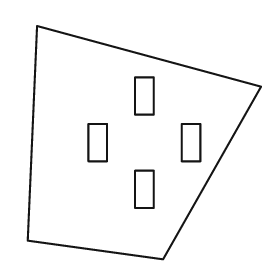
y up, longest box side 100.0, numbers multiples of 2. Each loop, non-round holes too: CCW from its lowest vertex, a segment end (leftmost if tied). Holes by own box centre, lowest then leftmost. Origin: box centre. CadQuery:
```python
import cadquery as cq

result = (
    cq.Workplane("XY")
    .moveTo(8.0, -50.0)
    .lineTo(50.0, 24.0)
    .lineTo(-46.0, 50.0)
    .lineTo(-50.0, -42.0)
    .close()
    .moveTo(-4.0, -28.0)
    .lineTo(4.0, -28.0)
    .lineTo(4.0, -12.0)
    .lineTo(-4.0, -12.0)
    .close()
    .moveTo(-24.0, -8.0)
    .lineTo(-16.0, -8.0)
    .lineTo(-16.0, 8.0)
    .lineTo(-24.0, 8.0)
    .close()
    .moveTo(16.0, -8.0)
    .lineTo(24.0, -8.0)
    .lineTo(24.0, 8.0)
    .lineTo(16.0, 8.0)
    .close()
    .moveTo(-4.0, 12.0)
    .lineTo(4.0, 12.0)
    .lineTo(4.0, 28.0)
    .lineTo(-4.0, 28.0)
    .close()
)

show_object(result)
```